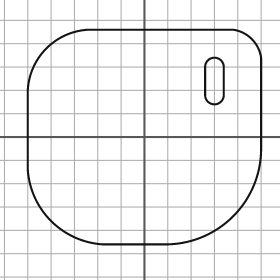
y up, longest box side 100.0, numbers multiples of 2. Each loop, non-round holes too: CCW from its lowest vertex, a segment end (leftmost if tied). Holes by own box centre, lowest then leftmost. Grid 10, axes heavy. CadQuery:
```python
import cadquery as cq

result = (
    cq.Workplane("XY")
    .moveTo(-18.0, -46.0)
    .lineTo(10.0, -46.0)
    .threePointArc((38.0, -34.0), (50.0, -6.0))
    .lineTo(50.0, 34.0)
    .threePointArc((46.0, 42.0), (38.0, 46.0))
    .lineTo(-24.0, 46.0)
    .threePointArc((-42.0, 38.0), (-50.0, 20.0))
    .lineTo(-50.0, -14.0)
    .threePointArc((-40.0, -36.0), (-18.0, -46.0))
    .close()
    .moveTo(26.0, 18.0)
    .threePointArc((30.0, 14.0), (34.0, 18.0))
    .lineTo(34.0, 30.0)
    .threePointArc((30.0, 34.0), (26.0, 30.0))
    .close()
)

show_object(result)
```